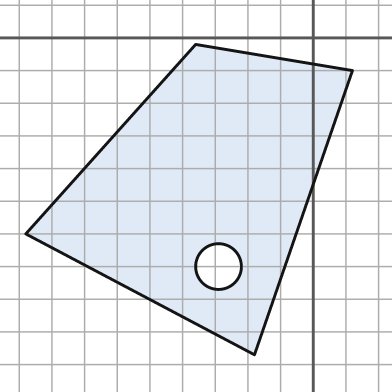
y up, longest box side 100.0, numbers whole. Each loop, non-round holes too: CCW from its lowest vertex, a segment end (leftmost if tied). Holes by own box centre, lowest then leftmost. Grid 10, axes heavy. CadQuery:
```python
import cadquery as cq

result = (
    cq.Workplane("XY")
    .moveTo(-18.0, -97.0)
    .lineTo(12.0, -10.0)
    .lineTo(-36.0, -2.0)
    .lineTo(-88.0, -60.0)
    .close()
    .moveTo(-29.0, -70.0)
    .circle(7.0)
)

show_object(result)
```